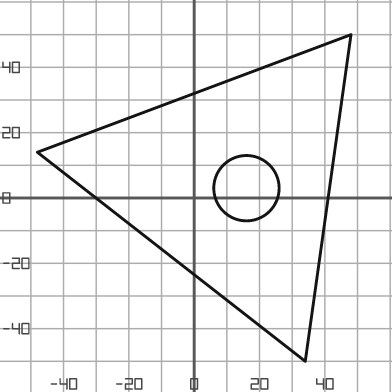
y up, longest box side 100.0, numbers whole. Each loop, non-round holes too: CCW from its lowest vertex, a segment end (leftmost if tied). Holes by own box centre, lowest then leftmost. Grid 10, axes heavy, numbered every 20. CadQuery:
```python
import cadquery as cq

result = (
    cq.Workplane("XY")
    .moveTo(34.0, -50.0)
    .lineTo(48.0, 50.0)
    .lineTo(-48.0, 14.0)
    .close()
    .moveTo(16.0, 3.0)
    .circle(10.0)
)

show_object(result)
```